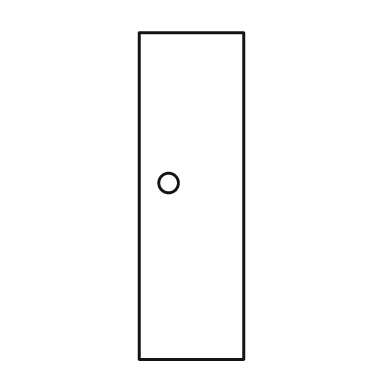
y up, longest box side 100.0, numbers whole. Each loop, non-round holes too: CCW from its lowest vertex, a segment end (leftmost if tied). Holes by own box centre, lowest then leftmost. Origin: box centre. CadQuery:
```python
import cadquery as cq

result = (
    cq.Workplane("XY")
    .moveTo(-16.0, -50.0)
    .lineTo(16.0, -50.0)
    .lineTo(16.0, 50.0)
    .lineTo(-16.0, 50.0)
    .close()
    .moveTo(-7.0, 4.0)
    .circle(3.0)
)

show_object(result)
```